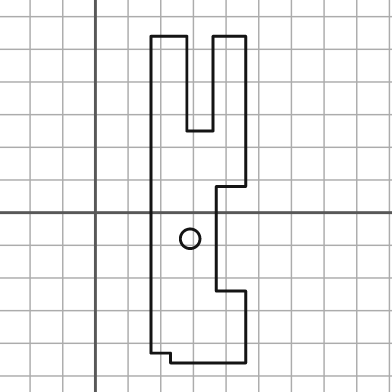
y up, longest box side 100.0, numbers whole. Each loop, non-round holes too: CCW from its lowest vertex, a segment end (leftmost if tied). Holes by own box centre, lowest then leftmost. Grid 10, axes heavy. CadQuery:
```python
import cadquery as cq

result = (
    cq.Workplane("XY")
    .moveTo(23.0, -46.0)
    .lineTo(46.0, -46.0)
    .lineTo(46.0, -24.0)
    .lineTo(37.0, -24.0)
    .lineTo(37.0, 8.0)
    .lineTo(46.0, 8.0)
    .lineTo(46.0, 54.0)
    .lineTo(36.0, 54.0)
    .lineTo(36.0, 25.0)
    .lineTo(28.0, 25.0)
    .lineTo(28.0, 54.0)
    .lineTo(17.0, 54.0)
    .lineTo(17.0, -43.0)
    .lineTo(23.0, -43.0)
    .close()
    .moveTo(29.0, -8.0)
    .circle(3.0)
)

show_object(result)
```